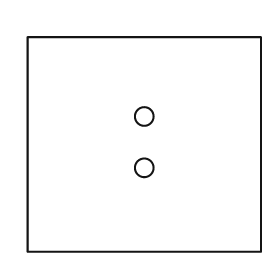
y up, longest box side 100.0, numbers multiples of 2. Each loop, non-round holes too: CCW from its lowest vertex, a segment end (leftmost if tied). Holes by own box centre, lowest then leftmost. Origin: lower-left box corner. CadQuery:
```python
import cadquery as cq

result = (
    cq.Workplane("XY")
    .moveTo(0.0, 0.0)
    .lineTo(100.0, 0.0)
    .lineTo(100.0, 92.0)
    .lineTo(0.0, 92.0)
    .close()
    .moveTo(50.0, 36.0)
    .circle(4.0)
    .moveTo(50.0, 58.0)
    .circle(4.0)
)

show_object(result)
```